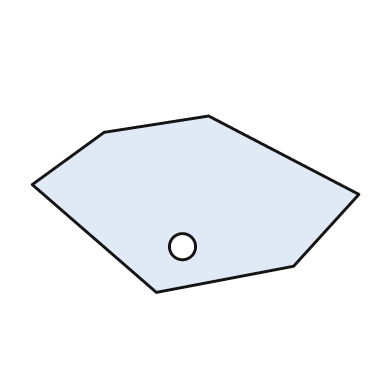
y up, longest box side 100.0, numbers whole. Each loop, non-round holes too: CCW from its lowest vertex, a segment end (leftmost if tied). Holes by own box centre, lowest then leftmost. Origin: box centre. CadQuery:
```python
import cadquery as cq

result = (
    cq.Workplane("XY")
    .moveTo(-12.0, -27.0)
    .lineTo(30.0, -19.0)
    .lineTo(50.0, 3.0)
    .lineTo(4.0, 27.0)
    .lineTo(-28.0, 22.0)
    .lineTo(-50.0, 6.0)
    .close()
    .moveTo(-4.0, -13.0)
    .circle(4.0)
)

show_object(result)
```